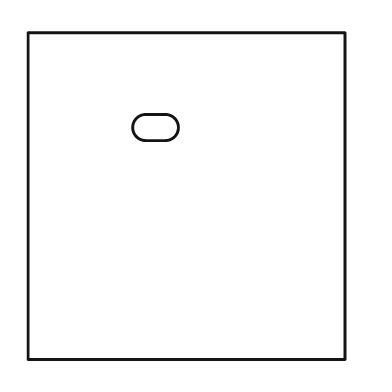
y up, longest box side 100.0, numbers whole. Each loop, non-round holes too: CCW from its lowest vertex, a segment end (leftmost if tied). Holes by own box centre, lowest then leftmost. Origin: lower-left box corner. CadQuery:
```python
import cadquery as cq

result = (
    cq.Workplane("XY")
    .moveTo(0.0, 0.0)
    .lineTo(97.0, 0.0)
    .lineTo(97.0, 100.0)
    .lineTo(0.0, 100.0)
    .close()
    .moveTo(36.0, 67.0)
    .lineTo(42.0, 67.0)
    .threePointArc((46.0, 71.0), (42.0, 75.0))
    .lineTo(36.0, 75.0)
    .threePointArc((32.0, 71.0), (36.0, 67.0))
    .close()
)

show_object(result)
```